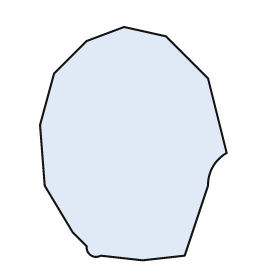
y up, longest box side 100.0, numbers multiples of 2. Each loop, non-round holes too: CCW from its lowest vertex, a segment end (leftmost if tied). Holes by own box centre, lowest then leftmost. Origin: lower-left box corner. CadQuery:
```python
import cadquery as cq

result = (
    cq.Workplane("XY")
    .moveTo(44.0, 0.0)
    .lineTo(62.0, 2.0)
    .lineTo(72.0, 32.0)
    .threePointArc((74.0, 40.0), (80.0, 46.0))
    .lineTo(72.0, 78.0)
    .lineTo(54.0, 96.0)
    .lineTo(36.0, 100.0)
    .lineTo(20.0, 94.0)
    .lineTo(6.0, 80.0)
    .lineTo(0.0, 58.0)
    .lineTo(2.0, 32.0)
    .lineTo(14.0, 12.0)
    .lineTo(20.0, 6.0)
    .threePointArc((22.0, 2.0), (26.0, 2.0))
    .close()
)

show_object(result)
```